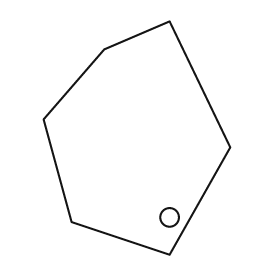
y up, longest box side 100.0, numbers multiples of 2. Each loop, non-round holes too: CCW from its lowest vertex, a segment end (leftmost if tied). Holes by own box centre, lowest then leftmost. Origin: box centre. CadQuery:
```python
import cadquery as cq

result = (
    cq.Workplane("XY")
    .moveTo(14.0, -50.0)
    .lineTo(40.0, -4.0)
    .lineTo(14.0, 50.0)
    .lineTo(-14.0, 38.0)
    .lineTo(-40.0, 8.0)
    .lineTo(-28.0, -36.0)
    .close()
    .moveTo(14.0, -34.0)
    .circle(4.0)
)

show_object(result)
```